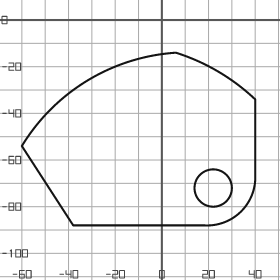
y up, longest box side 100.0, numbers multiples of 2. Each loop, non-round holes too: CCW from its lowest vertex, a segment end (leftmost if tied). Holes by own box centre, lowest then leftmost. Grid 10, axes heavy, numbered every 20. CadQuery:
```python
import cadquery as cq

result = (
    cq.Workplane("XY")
    .moveTo(-38.0, -88.0)
    .lineTo(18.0, -88.0)
    .threePointArc((34.0, -82.0), (40.0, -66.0))
    .lineTo(40.0, -34.0)
    .threePointArc((24.0, -22.0), (6.0, -14.0))
    .threePointArc((-32.0, -26.0), (-60.0, -54.0))
    .close()
    .moveTo(22.0, -72.0)
    .circle(8.0)
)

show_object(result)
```